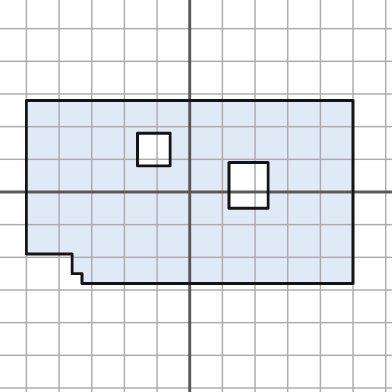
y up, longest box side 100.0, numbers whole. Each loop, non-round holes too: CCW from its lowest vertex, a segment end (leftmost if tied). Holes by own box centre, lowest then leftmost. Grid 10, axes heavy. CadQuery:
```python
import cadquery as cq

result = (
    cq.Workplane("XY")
    .moveTo(-33.0, -28.0)
    .lineTo(50.0, -28.0)
    .lineTo(50.0, 28.0)
    .lineTo(-50.0, 28.0)
    .lineTo(-50.0, -19.0)
    .lineTo(-36.0, -19.0)
    .lineTo(-36.0, -25.0)
    .lineTo(-33.0, -25.0)
    .close()
    .moveTo(12.0, -5.0)
    .lineTo(24.0, -5.0)
    .lineTo(24.0, 9.0)
    .lineTo(12.0, 9.0)
    .close()
    .moveTo(-16.0, 8.0)
    .lineTo(-6.0, 8.0)
    .lineTo(-6.0, 18.0)
    .lineTo(-16.0, 18.0)
    .close()
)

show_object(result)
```